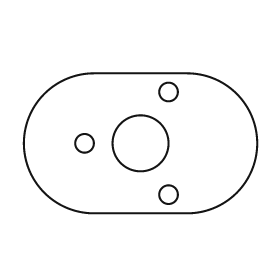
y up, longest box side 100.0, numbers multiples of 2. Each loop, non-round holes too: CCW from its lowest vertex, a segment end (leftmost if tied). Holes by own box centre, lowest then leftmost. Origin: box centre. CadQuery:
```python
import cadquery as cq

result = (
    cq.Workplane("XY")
    .moveTo(-20.0, -30.0)
    .lineTo(20.0, -30.0)
    .threePointArc((50.0, 0.0), (20.0, 30.0))
    .lineTo(-20.0, 30.0)
    .threePointArc((-50.0, 0.0), (-20.0, -30.0))
    .close()
    .moveTo(12.0, -22.0)
    .circle(4.0)
    .moveTo(-24.0, 0.0)
    .circle(4.0)
    .moveTo(0.0, 0.0)
    .circle(12.0)
    .moveTo(12.0, 22.0)
    .circle(4.0)
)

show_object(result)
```